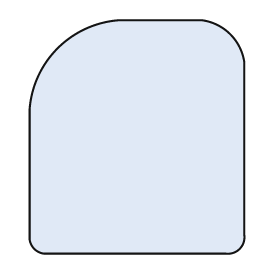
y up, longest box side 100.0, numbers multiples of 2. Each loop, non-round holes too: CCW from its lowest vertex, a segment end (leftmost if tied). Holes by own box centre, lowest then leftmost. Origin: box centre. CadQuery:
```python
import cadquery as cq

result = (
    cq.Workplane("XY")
    .moveTo(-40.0, -50.0)
    .lineTo(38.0, -50.0)
    .threePointArc((44.0, -48.0), (46.0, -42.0))
    .lineTo(46.0, 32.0)
    .threePointArc((40.0, 44.0), (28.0, 50.0))
    .lineTo(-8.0, 50.0)
    .threePointArc((-34.0, 38.0), (-46.0, 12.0))
    .lineTo(-46.0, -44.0)
    .threePointArc((-44.0, -48.0), (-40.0, -50.0))
    .close()
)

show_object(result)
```